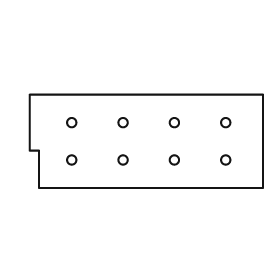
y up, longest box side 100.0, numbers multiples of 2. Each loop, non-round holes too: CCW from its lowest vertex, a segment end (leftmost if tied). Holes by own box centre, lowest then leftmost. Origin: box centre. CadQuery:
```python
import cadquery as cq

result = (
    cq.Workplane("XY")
    .moveTo(-46.0, -20.0)
    .lineTo(50.0, -20.0)
    .lineTo(50.0, 20.0)
    .lineTo(-50.0, 20.0)
    .lineTo(-50.0, -4.0)
    .lineTo(-46.0, -4.0)
    .close()
    .moveTo(-32.0, -8.0)
    .circle(2.0)
    .moveTo(-10.0, -8.0)
    .circle(2.0)
    .moveTo(12.0, -8.0)
    .circle(2.0)
    .moveTo(34.0, -8.0)
    .circle(2.0)
    .moveTo(-32.0, 8.0)
    .circle(2.0)
    .moveTo(-10.0, 8.0)
    .circle(2.0)
    .moveTo(12.0, 8.0)
    .circle(2.0)
    .moveTo(34.0, 8.0)
    .circle(2.0)
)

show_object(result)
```